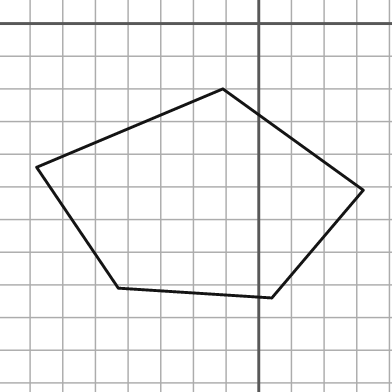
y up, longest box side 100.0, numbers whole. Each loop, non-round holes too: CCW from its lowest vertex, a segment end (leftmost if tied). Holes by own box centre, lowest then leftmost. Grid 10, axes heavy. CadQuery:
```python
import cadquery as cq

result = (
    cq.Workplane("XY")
    .moveTo(4.0, -84.0)
    .lineTo(32.0, -51.0)
    .lineTo(-11.0, -20.0)
    .lineTo(-68.0, -44.0)
    .lineTo(-43.0, -81.0)
    .close()
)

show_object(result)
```